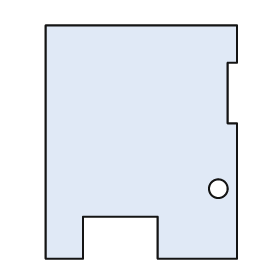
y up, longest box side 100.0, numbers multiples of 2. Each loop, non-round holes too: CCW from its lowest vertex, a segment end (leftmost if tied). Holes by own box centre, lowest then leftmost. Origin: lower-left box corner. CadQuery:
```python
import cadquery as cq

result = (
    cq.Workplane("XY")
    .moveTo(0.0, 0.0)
    .lineTo(16.0, 0.0)
    .lineTo(16.0, 18.0)
    .lineTo(48.0, 18.0)
    .lineTo(48.0, 0.0)
    .lineTo(82.0, 0.0)
    .lineTo(82.0, 58.0)
    .lineTo(78.0, 58.0)
    .lineTo(78.0, 84.0)
    .lineTo(82.0, 84.0)
    .lineTo(82.0, 100.0)
    .lineTo(0.0, 100.0)
    .close()
    .moveTo(74.0, 30.0)
    .circle(4.0)
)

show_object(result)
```